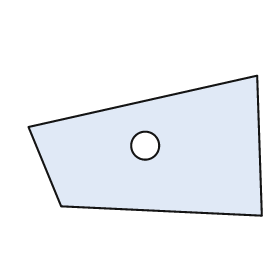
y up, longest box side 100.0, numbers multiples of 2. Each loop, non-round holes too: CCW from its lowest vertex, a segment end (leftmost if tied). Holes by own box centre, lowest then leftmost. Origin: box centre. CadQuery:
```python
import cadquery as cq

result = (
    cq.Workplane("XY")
    .moveTo(50.0, -30.0)
    .lineTo(48.0, 30.0)
    .lineTo(-50.0, 8.0)
    .lineTo(-36.0, -26.0)
    .close()
    .moveTo(0.0, 0.0)
    .circle(6.0)
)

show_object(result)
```